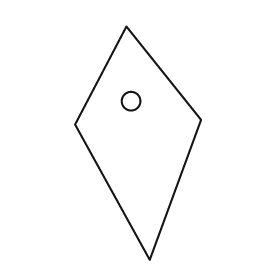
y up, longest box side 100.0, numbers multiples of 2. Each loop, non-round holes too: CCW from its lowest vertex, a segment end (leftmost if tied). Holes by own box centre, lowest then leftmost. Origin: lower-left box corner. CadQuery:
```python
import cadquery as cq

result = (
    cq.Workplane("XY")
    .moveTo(32.0, 0.0)
    .lineTo(54.0, 60.0)
    .lineTo(22.0, 100.0)
    .lineTo(0.0, 58.0)
    .close()
    .moveTo(24.0, 68.0)
    .circle(4.0)
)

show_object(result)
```